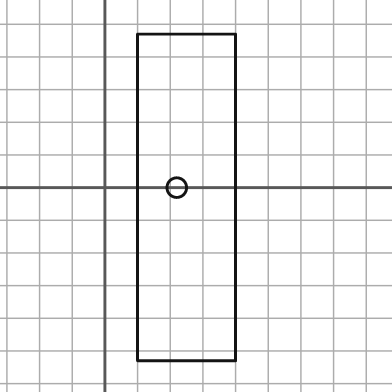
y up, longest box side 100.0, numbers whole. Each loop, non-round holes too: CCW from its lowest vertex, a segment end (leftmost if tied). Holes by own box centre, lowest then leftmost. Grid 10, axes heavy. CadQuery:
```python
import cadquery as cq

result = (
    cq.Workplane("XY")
    .moveTo(10.0, -53.0)
    .lineTo(40.0, -53.0)
    .lineTo(40.0, 47.0)
    .lineTo(10.0, 47.0)
    .close()
    .moveTo(22.0, 0.0)
    .circle(3.0)
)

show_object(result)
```